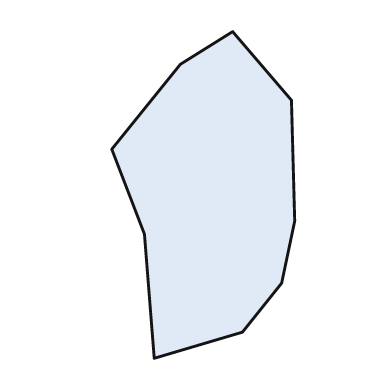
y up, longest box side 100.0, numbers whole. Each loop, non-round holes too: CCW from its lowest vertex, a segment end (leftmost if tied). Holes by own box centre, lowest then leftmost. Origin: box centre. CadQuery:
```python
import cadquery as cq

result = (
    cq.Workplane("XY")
    .moveTo(-15.0, -50.0)
    .lineTo(12.0, -42.0)
    .lineTo(24.0, -27.0)
    .lineTo(28.0, -8.0)
    .lineTo(27.0, 29.0)
    .lineTo(9.0, 50.0)
    .lineTo(-7.0, 40.0)
    .lineTo(-28.0, 14.0)
    .lineTo(-18.0, -12.0)
    .close()
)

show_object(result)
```